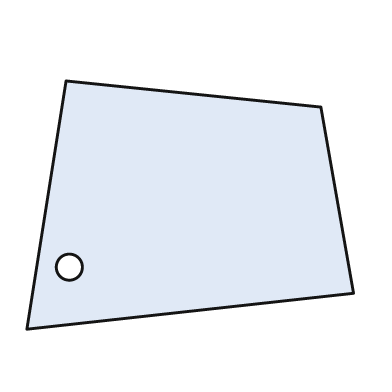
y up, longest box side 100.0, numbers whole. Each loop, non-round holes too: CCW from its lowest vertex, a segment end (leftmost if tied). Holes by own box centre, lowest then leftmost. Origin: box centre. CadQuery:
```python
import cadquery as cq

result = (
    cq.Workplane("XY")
    .moveTo(-50.0, -38.0)
    .lineTo(50.0, -27.0)
    .lineTo(40.0, 30.0)
    .lineTo(-38.0, 38.0)
    .close()
    .moveTo(-37.0, -19.0)
    .circle(4.0)
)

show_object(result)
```